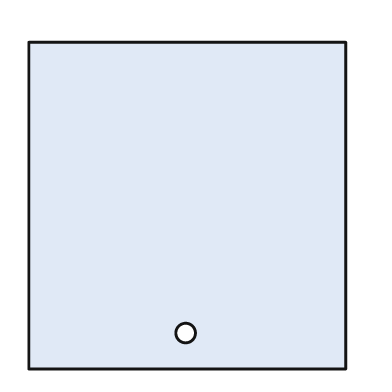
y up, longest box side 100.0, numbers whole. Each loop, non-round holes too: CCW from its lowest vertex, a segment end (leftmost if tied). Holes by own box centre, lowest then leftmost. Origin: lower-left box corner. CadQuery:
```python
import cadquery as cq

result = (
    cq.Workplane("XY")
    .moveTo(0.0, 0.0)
    .lineTo(97.0, 0.0)
    .lineTo(97.0, 100.0)
    .lineTo(0.0, 100.0)
    .close()
    .moveTo(48.0, 11.0)
    .circle(3.0)
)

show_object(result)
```